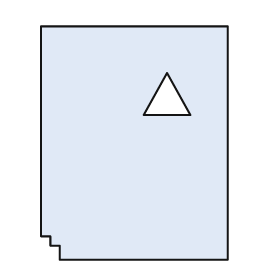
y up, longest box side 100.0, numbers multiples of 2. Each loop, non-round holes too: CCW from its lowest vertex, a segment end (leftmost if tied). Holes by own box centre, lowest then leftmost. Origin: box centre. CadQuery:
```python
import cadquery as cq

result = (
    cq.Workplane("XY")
    .moveTo(-32.0, -50.0)
    .lineTo(40.0, -50.0)
    .lineTo(40.0, 50.0)
    .lineTo(-40.0, 50.0)
    .lineTo(-40.0, -40.0)
    .lineTo(-36.0, -40.0)
    .lineTo(-36.0, -44.0)
    .lineTo(-32.0, -44.0)
    .close()
    .moveTo(4.0, 12.0)
    .lineTo(24.0, 12.0)
    .lineTo(14.0, 30.0)
    .close()
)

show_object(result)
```